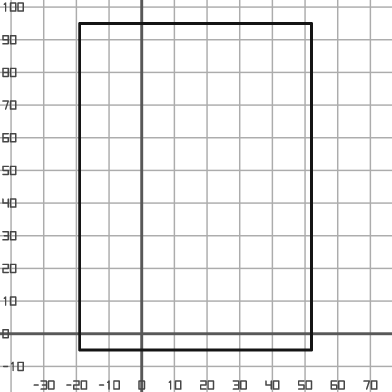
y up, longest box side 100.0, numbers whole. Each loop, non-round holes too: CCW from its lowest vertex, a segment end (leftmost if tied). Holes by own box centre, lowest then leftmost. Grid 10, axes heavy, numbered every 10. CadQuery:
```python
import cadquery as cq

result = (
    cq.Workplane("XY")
    .moveTo(-19.0, -5.0)
    .lineTo(52.0, -5.0)
    .lineTo(52.0, 95.0)
    .lineTo(-19.0, 95.0)
    .close()
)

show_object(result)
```